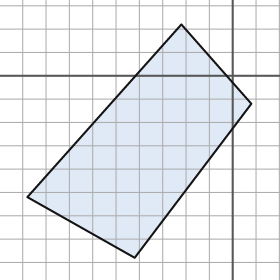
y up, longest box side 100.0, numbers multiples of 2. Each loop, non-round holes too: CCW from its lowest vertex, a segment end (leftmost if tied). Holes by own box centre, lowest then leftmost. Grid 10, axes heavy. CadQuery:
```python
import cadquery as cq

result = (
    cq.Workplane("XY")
    .moveTo(-42.0, -78.0)
    .lineTo(8.0, -12.0)
    .lineTo(-22.0, 22.0)
    .lineTo(-88.0, -52.0)
    .close()
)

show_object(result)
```